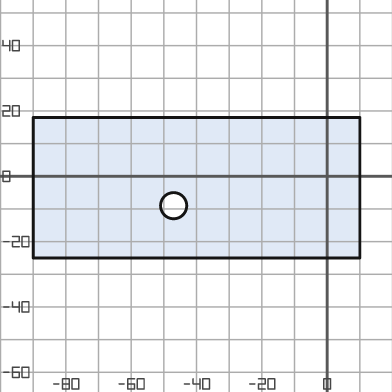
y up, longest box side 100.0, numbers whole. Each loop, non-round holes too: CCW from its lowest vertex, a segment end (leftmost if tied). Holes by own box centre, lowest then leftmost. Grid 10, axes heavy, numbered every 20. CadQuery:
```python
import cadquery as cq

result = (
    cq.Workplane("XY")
    .moveTo(-90.0, -25.0)
    .lineTo(10.0, -25.0)
    .lineTo(10.0, 18.0)
    .lineTo(-90.0, 18.0)
    .close()
    .moveTo(-47.0, -9.0)
    .circle(4.0)
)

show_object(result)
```